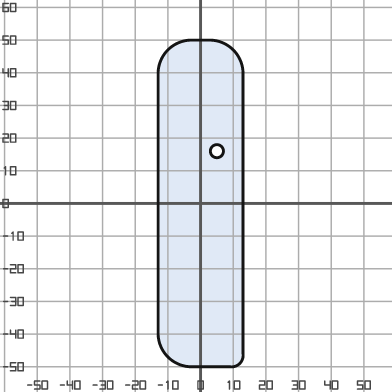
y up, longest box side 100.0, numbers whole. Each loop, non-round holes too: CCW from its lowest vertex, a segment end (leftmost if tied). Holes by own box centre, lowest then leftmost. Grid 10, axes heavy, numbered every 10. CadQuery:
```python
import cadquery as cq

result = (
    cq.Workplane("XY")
    .moveTo(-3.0, -50.0)
    .lineTo(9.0, -50.0)
    .threePointArc((12.0, -49.0), (13.0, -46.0))
    .lineTo(13.0, 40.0)
    .threePointArc((10.0, 47.0), (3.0, 50.0))
    .lineTo(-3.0, 50.0)
    .threePointArc((-10.0, 47.0), (-13.0, 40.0))
    .lineTo(-13.0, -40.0)
    .threePointArc((-10.0, -47.0), (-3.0, -50.0))
    .close()
    .moveTo(5.0, 16.0)
    .circle(2.0)
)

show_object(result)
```